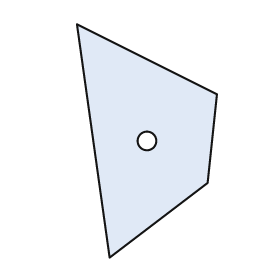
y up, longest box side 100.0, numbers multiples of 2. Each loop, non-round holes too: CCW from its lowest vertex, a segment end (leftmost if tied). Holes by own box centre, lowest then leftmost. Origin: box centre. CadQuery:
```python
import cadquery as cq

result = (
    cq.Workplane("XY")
    .moveTo(-16.0, -50.0)
    .lineTo(26.0, -18.0)
    .lineTo(30.0, 20.0)
    .lineTo(-30.0, 50.0)
    .close()
    .moveTo(0.0, 0.0)
    .circle(4.0)
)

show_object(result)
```